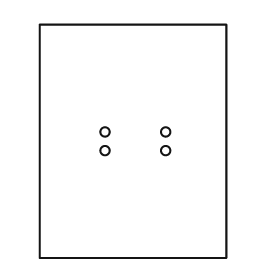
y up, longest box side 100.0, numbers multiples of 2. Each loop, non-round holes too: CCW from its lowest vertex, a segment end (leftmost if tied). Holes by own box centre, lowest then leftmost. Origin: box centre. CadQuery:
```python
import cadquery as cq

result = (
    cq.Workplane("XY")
    .moveTo(-40.0, -50.0)
    .lineTo(40.0, -50.0)
    .lineTo(40.0, 50.0)
    .lineTo(-40.0, 50.0)
    .close()
    .moveTo(-12.0, -4.0)
    .circle(2.0)
    .moveTo(14.0, -4.0)
    .circle(2.0)
    .moveTo(-12.0, 4.0)
    .circle(2.0)
    .moveTo(14.0, 4.0)
    .circle(2.0)
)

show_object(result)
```